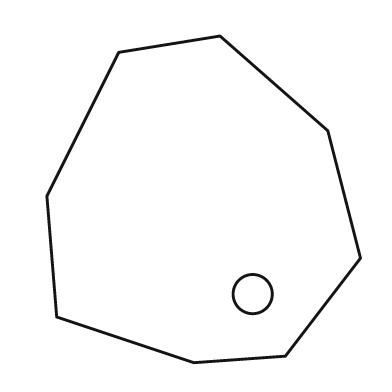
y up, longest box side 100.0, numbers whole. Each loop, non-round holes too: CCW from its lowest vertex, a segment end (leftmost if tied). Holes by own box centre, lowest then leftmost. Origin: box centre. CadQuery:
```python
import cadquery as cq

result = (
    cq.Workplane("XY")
    .moveTo(-3.0, -50.0)
    .lineTo(25.0, -48.0)
    .lineTo(48.0, -18.0)
    .lineTo(38.0, 21.0)
    .lineTo(5.0, 50.0)
    .lineTo(-26.0, 45.0)
    .lineTo(-48.0, 1.0)
    .lineTo(-45.0, -36.0)
    .close()
    .moveTo(15.0, -29.0)
    .circle(6.0)
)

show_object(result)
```